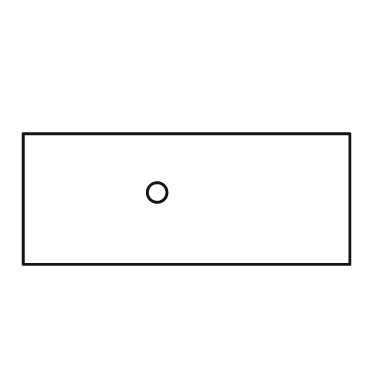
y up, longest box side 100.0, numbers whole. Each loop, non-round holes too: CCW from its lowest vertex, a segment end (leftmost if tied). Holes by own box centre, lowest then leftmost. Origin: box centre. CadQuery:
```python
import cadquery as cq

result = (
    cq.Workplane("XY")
    .moveTo(-50.0, -20.0)
    .lineTo(50.0, -20.0)
    .lineTo(50.0, 20.0)
    .lineTo(-50.0, 20.0)
    .close()
    .moveTo(-9.0, 2.0)
    .circle(3.0)
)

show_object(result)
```